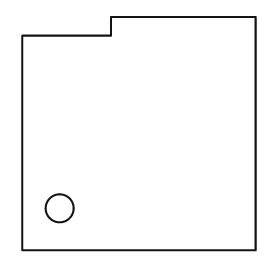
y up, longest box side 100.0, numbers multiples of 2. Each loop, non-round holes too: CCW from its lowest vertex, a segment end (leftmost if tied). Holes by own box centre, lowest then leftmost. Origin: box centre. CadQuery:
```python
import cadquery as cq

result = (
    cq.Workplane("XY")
    .moveTo(-50.0, -50.0)
    .lineTo(50.0, -50.0)
    .lineTo(50.0, 50.0)
    .lineTo(-12.0, 50.0)
    .lineTo(-12.0, 42.0)
    .lineTo(-50.0, 42.0)
    .close()
    .moveTo(-34.0, -32.0)
    .circle(6.0)
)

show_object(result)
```